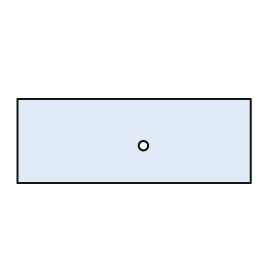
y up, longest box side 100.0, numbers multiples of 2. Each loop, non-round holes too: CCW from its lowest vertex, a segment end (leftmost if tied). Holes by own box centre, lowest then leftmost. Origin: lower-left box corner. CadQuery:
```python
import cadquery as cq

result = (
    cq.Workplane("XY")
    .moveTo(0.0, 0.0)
    .lineTo(100.0, 0.0)
    .lineTo(100.0, 36.0)
    .lineTo(0.0, 36.0)
    .close()
    .moveTo(54.0, 16.0)
    .circle(2.0)
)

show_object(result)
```